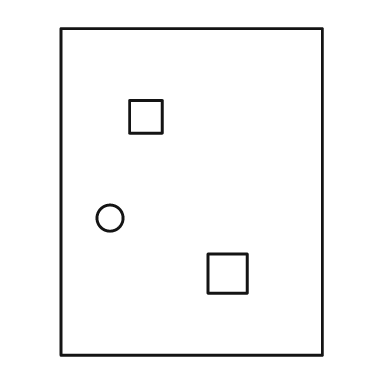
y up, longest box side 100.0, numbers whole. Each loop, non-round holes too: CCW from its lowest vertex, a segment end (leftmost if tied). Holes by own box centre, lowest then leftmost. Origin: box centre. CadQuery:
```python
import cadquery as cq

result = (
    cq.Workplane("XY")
    .moveTo(-40.0, -50.0)
    .lineTo(40.0, -50.0)
    .lineTo(40.0, 50.0)
    .lineTo(-40.0, 50.0)
    .close()
    .moveTo(5.0, -31.0)
    .lineTo(17.0, -31.0)
    .lineTo(17.0, -19.0)
    .lineTo(5.0, -19.0)
    .close()
    .moveTo(-25.0, -8.0)
    .circle(4.0)
    .moveTo(-19.0, 18.0)
    .lineTo(-9.0, 18.0)
    .lineTo(-9.0, 28.0)
    .lineTo(-19.0, 28.0)
    .close()
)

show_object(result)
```